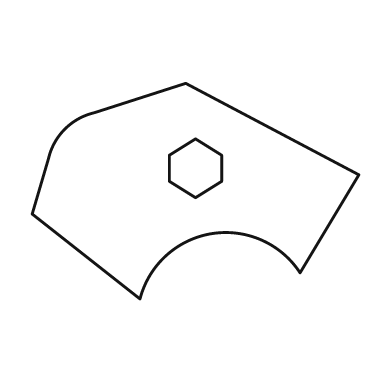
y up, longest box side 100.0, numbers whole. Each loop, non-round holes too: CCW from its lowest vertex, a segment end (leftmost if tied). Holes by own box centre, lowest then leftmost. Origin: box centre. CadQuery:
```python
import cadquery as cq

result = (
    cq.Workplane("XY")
    .moveTo(-17.0, -33.0)
    .threePointArc((5.0, -13.0), (32.0, -25.0))
    .lineTo(50.0, 5.0)
    .lineTo(-3.0, 33.0)
    .lineTo(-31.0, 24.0)
    .threePointArc((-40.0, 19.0), (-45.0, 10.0))
    .lineTo(-50.0, -7.0)
    .close()
    .moveTo(0.0, -2.0)
    .lineTo(8.0, 3.0)
    .lineTo(8.0, 11.0)
    .lineTo(0.0, 16.0)
    .lineTo(-8.0, 11.0)
    .lineTo(-8.0, 3.0)
    .close()
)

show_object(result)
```